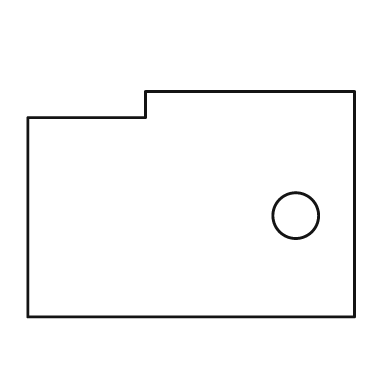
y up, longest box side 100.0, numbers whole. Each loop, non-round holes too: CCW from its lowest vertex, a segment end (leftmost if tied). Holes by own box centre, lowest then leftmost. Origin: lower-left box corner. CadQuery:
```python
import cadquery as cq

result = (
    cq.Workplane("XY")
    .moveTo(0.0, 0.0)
    .lineTo(100.0, 0.0)
    .lineTo(100.0, 69.0)
    .lineTo(36.0, 69.0)
    .lineTo(36.0, 61.0)
    .lineTo(0.0, 61.0)
    .close()
    .moveTo(82.0, 31.0)
    .circle(7.0)
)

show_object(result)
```